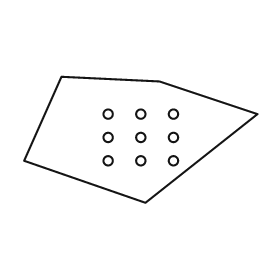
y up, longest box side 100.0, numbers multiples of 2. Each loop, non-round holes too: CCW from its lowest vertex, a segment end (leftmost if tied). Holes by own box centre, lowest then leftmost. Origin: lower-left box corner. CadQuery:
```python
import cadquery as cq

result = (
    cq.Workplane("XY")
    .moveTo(52.0, 0.0)
    .lineTo(100.0, 38.0)
    .lineTo(58.0, 52.0)
    .lineTo(16.0, 54.0)
    .lineTo(0.0, 18.0)
    .close()
    .moveTo(36.0, 18.0)
    .circle(2.0)
    .moveTo(50.0, 18.0)
    .circle(2.0)
    .moveTo(64.0, 18.0)
    .circle(2.0)
    .moveTo(36.0, 28.0)
    .circle(2.0)
    .moveTo(50.0, 28.0)
    .circle(2.0)
    .moveTo(64.0, 28.0)
    .circle(2.0)
    .moveTo(36.0, 38.0)
    .circle(2.0)
    .moveTo(50.0, 38.0)
    .circle(2.0)
    .moveTo(64.0, 38.0)
    .circle(2.0)
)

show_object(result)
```